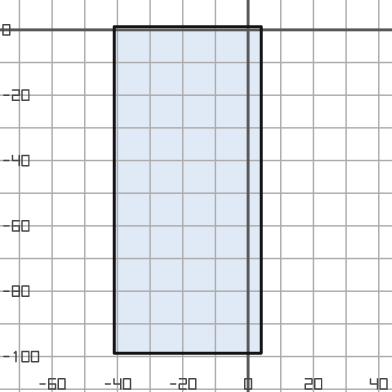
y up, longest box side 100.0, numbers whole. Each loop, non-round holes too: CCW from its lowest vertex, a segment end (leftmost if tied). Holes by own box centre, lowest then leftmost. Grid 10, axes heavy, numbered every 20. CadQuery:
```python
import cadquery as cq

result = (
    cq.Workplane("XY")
    .moveTo(-41.0, -99.0)
    .lineTo(4.0, -99.0)
    .lineTo(4.0, 1.0)
    .lineTo(-41.0, 1.0)
    .close()
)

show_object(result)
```